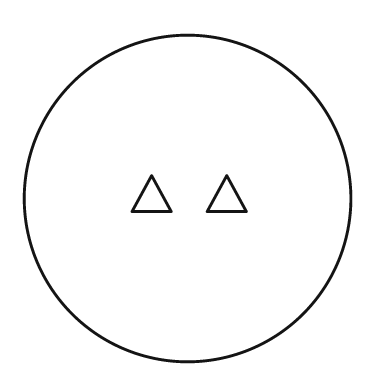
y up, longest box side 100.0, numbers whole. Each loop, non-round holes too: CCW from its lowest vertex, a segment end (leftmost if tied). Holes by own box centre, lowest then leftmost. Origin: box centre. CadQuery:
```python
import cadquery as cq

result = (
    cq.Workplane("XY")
    .moveTo(0.0, 0.0)
    .circle(50.0)
    .moveTo(-17.0, -4.0)
    .lineTo(-5.0, -4.0)
    .lineTo(-11.0, 7.0)
    .close()
    .moveTo(6.0, -4.0)
    .lineTo(18.0, -4.0)
    .lineTo(12.0, 7.0)
    .close()
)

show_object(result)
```